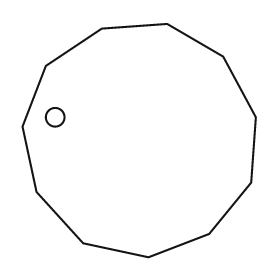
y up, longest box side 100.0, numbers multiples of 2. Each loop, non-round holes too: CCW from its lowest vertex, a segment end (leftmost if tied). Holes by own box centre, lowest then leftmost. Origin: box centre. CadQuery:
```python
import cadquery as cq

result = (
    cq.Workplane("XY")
    .moveTo(4.0, -50.0)
    .lineTo(30.0, -40.0)
    .lineTo(48.0, -18.0)
    .lineTo(50.0, 10.0)
    .lineTo(36.0, 36.0)
    .lineTo(12.0, 50.0)
    .lineTo(-16.0, 48.0)
    .lineTo(-40.0, 32.0)
    .lineTo(-50.0, 6.0)
    .lineTo(-44.0, -22.0)
    .lineTo(-24.0, -44.0)
    .close()
    .moveTo(-36.0, 10.0)
    .circle(4.0)
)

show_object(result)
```